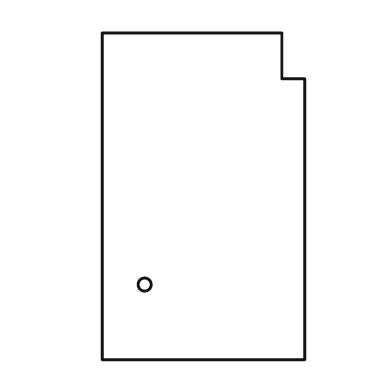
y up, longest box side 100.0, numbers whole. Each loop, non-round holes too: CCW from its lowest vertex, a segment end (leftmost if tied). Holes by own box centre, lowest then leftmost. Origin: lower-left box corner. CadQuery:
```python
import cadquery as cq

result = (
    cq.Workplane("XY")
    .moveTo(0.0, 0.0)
    .lineTo(62.0, 0.0)
    .lineTo(62.0, 86.0)
    .lineTo(55.0, 86.0)
    .lineTo(55.0, 100.0)
    .lineTo(0.0, 100.0)
    .close()
    .moveTo(13.0, 23.0)
    .circle(2.0)
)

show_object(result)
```